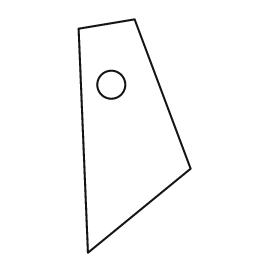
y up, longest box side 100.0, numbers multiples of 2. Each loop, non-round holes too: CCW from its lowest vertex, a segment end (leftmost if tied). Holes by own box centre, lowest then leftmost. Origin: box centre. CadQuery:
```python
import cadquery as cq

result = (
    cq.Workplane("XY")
    .moveTo(-20.0, -50.0)
    .lineTo(24.0, -14.0)
    .lineTo(0.0, 50.0)
    .lineTo(-24.0, 46.0)
    .close()
    .moveTo(-10.0, 22.0)
    .circle(6.0)
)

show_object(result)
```